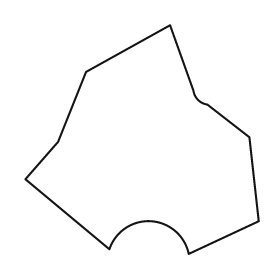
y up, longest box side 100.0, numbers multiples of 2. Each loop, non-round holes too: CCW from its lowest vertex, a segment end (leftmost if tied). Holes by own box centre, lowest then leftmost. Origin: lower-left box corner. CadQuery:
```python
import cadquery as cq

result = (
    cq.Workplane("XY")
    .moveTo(70.0, 0.0)
    .lineTo(100.0, 14.0)
    .lineTo(96.0, 50.0)
    .lineTo(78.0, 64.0)
    .threePointArc((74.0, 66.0), (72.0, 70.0))
    .lineTo(62.0, 98.0)
    .lineTo(26.0, 78.0)
    .lineTo(14.0, 48.0)
    .lineTo(0.0, 32.0)
    .lineTo(36.0, 2.0)
    .threePointArc((54.0, 14.0), (70.0, 0.0))
    .close()
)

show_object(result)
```